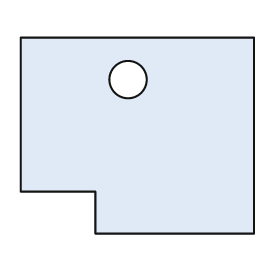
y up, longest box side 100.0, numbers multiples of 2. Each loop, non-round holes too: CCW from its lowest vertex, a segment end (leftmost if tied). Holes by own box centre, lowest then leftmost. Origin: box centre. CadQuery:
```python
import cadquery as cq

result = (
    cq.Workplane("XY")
    .moveTo(-18.0, -42.0)
    .lineTo(50.0, -42.0)
    .lineTo(50.0, 42.0)
    .lineTo(-50.0, 42.0)
    .lineTo(-50.0, -24.0)
    .lineTo(-18.0, -24.0)
    .close()
    .moveTo(-4.0, 24.0)
    .circle(8.0)
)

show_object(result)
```